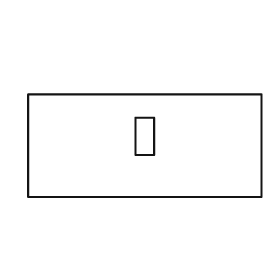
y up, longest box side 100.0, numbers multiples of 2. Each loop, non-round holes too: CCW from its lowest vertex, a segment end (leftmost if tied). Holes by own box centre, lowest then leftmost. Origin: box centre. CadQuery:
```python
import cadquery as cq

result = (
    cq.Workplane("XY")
    .moveTo(-50.0, -22.0)
    .lineTo(50.0, -22.0)
    .lineTo(50.0, 22.0)
    .lineTo(-50.0, 22.0)
    .close()
    .moveTo(-4.0, -4.0)
    .lineTo(4.0, -4.0)
    .lineTo(4.0, 12.0)
    .lineTo(-4.0, 12.0)
    .close()
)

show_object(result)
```